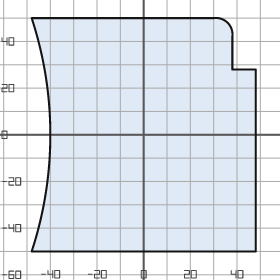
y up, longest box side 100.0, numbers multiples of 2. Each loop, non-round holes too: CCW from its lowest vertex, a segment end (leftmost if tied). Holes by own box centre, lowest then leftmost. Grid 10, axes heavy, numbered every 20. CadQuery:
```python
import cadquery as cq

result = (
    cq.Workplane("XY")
    .moveTo(-48.0, -50.0)
    .lineTo(48.0, -50.0)
    .lineTo(48.0, 28.0)
    .lineTo(38.0, 28.0)
    .lineTo(38.0, 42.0)
    .threePointArc((36.0, 48.0), (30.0, 50.0))
    .lineTo(-48.0, 50.0)
    .threePointArc((-40.0, 0.0), (-48.0, -50.0))
    .close()
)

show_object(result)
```